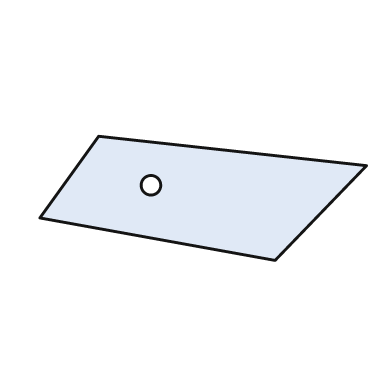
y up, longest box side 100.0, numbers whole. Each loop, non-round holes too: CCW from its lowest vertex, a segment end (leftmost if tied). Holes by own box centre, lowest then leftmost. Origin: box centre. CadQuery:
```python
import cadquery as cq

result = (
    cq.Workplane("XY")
    .moveTo(22.0, -19.0)
    .lineTo(50.0, 10.0)
    .lineTo(-32.0, 19.0)
    .lineTo(-50.0, -6.0)
    .close()
    .moveTo(-16.0, 4.0)
    .circle(3.0)
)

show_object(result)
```